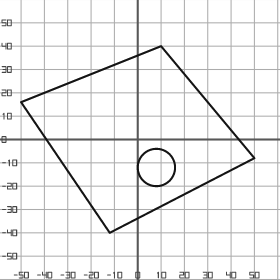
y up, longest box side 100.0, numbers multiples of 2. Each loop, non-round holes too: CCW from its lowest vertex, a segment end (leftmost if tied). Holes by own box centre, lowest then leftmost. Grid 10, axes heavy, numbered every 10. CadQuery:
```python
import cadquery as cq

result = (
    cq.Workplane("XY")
    .moveTo(-12.0, -40.0)
    .lineTo(50.0, -8.0)
    .lineTo(10.0, 40.0)
    .lineTo(-50.0, 16.0)
    .close()
    .moveTo(8.0, -12.0)
    .circle(8.0)
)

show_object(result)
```